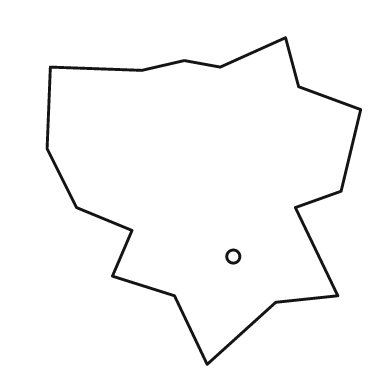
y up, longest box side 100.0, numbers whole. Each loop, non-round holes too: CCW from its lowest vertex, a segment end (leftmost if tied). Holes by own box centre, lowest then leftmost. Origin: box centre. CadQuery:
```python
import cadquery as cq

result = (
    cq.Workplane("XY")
    .moveTo(1.0, -50.0)
    .lineTo(22.0, -31.0)
    .lineTo(41.0, -29.0)
    .lineTo(28.0, -2.0)
    .lineTo(42.0, 3.0)
    .lineTo(48.0, 28.0)
    .lineTo(29.0, 35.0)
    .lineTo(25.0, 50.0)
    .lineTo(5.0, 41.0)
    .lineTo(-6.0, 43.0)
    .lineTo(-19.0, 40.0)
    .lineTo(-47.0, 41.0)
    .lineTo(-48.0, 16.0)
    .lineTo(-39.0, -2.0)
    .lineTo(-22.0, -9.0)
    .lineTo(-28.0, -23.0)
    .lineTo(-9.0, -29.0)
    .close()
    .moveTo(9.0, -17.0)
    .circle(2.0)
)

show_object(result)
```